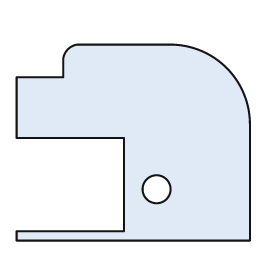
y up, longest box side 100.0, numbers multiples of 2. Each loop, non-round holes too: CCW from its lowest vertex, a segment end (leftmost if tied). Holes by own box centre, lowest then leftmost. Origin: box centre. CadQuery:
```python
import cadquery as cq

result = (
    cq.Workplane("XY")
    .moveTo(-50.0, -42.0)
    .lineTo(50.0, -42.0)
    .lineTo(50.0, 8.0)
    .threePointArc((40.0, 32.0), (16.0, 42.0))
    .lineTo(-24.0, 42.0)
    .threePointArc((-28.0, 40.0), (-30.0, 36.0))
    .lineTo(-30.0, 28.0)
    .lineTo(-50.0, 28.0)
    .lineTo(-50.0, 2.0)
    .lineTo(-4.0, 2.0)
    .lineTo(-4.0, -38.0)
    .lineTo(-50.0, -38.0)
    .close()
    .moveTo(10.0, -20.0)
    .circle(6.0)
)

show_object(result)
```